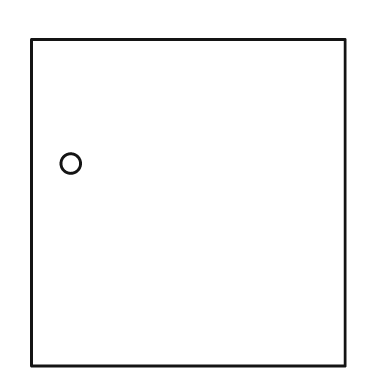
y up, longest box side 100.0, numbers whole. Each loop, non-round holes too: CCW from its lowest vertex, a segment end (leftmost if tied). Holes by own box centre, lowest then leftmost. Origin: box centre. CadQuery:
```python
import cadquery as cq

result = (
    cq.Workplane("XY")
    .moveTo(-48.0, -50.0)
    .lineTo(48.0, -50.0)
    .lineTo(48.0, 50.0)
    .lineTo(-48.0, 50.0)
    .close()
    .moveTo(-36.0, 12.0)
    .circle(3.0)
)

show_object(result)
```